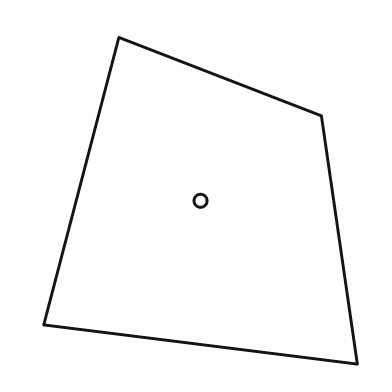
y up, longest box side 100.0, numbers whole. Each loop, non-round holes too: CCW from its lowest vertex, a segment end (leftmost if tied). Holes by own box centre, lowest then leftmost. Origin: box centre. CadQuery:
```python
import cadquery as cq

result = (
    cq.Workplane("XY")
    .moveTo(48.0, -50.0)
    .lineTo(37.0, 26.0)
    .lineTo(-25.0, 50.0)
    .lineTo(-48.0, -38.0)
    .close()
    .moveTo(0.0, 0.0)
    .circle(2.0)
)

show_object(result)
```